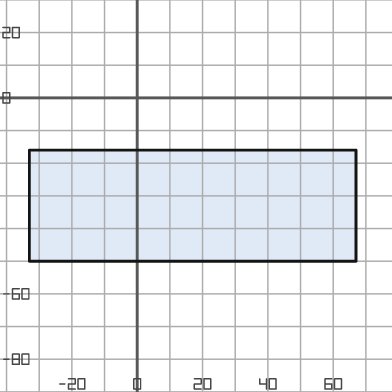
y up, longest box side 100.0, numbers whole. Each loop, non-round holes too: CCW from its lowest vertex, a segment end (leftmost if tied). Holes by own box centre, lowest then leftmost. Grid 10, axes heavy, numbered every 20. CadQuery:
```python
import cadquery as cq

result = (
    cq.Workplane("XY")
    .moveTo(-33.0, -50.0)
    .lineTo(67.0, -50.0)
    .lineTo(67.0, -16.0)
    .lineTo(-33.0, -16.0)
    .close()
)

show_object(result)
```